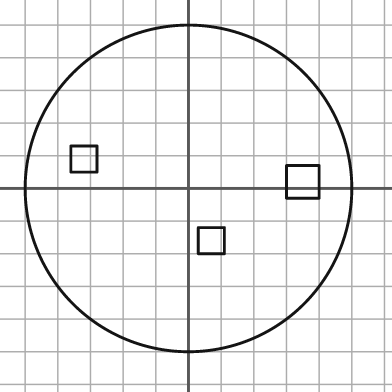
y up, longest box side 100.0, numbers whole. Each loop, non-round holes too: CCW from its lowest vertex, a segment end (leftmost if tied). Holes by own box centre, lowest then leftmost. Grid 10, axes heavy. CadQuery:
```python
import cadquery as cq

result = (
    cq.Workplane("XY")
    .moveTo(0.0, 0.0)
    .circle(50.0)
    .moveTo(3.0, -20.0)
    .lineTo(11.0, -20.0)
    .lineTo(11.0, -12.0)
    .lineTo(3.0, -12.0)
    .close()
    .moveTo(30.0, -3.0)
    .lineTo(40.0, -3.0)
    .lineTo(40.0, 7.0)
    .lineTo(30.0, 7.0)
    .close()
    .moveTo(-36.0, 5.0)
    .lineTo(-28.0, 5.0)
    .lineTo(-28.0, 13.0)
    .lineTo(-36.0, 13.0)
    .close()
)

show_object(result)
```